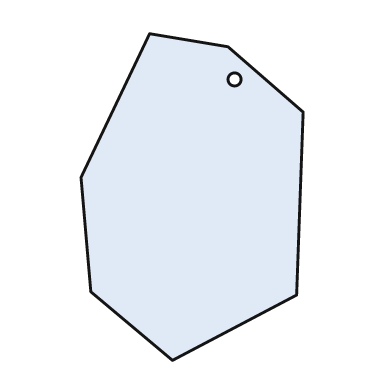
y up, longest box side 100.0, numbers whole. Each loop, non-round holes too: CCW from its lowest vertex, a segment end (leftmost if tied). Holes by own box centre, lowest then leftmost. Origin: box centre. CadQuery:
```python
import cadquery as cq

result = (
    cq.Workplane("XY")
    .moveTo(-6.0, -50.0)
    .lineTo(32.0, -30.0)
    .lineTo(34.0, 26.0)
    .lineTo(11.0, 46.0)
    .lineTo(-13.0, 50.0)
    .lineTo(-34.0, 6.0)
    .lineTo(-31.0, -29.0)
    .close()
    .moveTo(13.0, 36.0)
    .circle(2.0)
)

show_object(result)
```